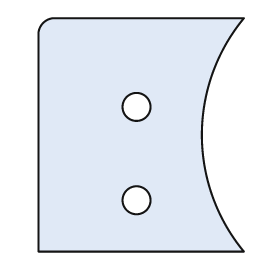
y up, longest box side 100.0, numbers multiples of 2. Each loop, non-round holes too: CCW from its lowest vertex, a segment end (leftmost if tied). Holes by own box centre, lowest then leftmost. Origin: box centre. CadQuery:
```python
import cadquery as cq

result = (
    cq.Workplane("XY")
    .moveTo(-44.0, -50.0)
    .lineTo(44.0, -50.0)
    .threePointArc((26.0, 0.0), (44.0, 50.0))
    .lineTo(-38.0, 50.0)
    .threePointArc((-42.0, 48.0), (-44.0, 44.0))
    .close()
    .moveTo(-2.0, -28.0)
    .circle(6.0)
    .moveTo(-2.0, 12.0)
    .circle(6.0)
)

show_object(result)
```